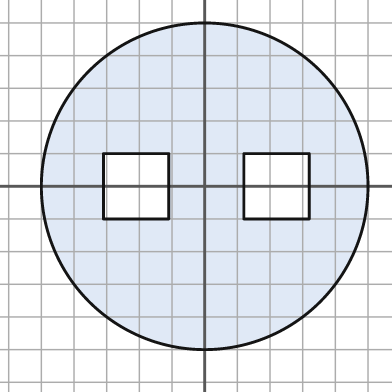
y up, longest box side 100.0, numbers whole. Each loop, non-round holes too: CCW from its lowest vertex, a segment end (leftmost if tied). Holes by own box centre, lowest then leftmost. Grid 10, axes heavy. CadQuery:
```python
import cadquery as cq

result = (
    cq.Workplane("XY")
    .moveTo(0.0, 0.0)
    .circle(50.0)
    .moveTo(-31.0, -10.0)
    .lineTo(-11.0, -10.0)
    .lineTo(-11.0, 10.0)
    .lineTo(-31.0, 10.0)
    .close()
    .moveTo(12.0, -10.0)
    .lineTo(32.0, -10.0)
    .lineTo(32.0, 10.0)
    .lineTo(12.0, 10.0)
    .close()
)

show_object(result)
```